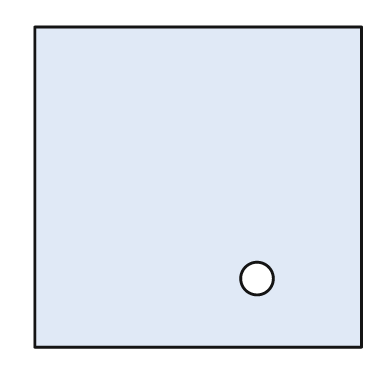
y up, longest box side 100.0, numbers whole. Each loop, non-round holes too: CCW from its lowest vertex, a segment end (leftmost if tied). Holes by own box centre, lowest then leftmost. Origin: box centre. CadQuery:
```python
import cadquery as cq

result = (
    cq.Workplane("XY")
    .moveTo(-50.0, -49.0)
    .lineTo(50.0, -49.0)
    .lineTo(50.0, 49.0)
    .lineTo(-50.0, 49.0)
    .close()
    .moveTo(18.0, -28.0)
    .circle(5.0)
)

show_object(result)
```